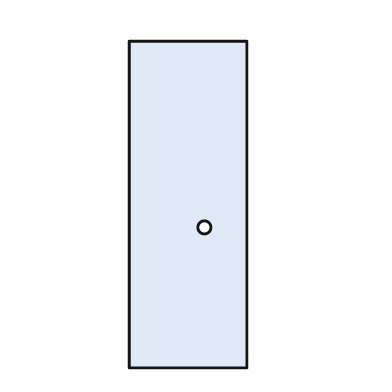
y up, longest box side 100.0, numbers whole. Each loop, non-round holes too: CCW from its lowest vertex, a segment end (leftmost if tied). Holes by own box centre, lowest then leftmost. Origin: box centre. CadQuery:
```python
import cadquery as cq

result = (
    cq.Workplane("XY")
    .moveTo(-18.0, -50.0)
    .lineTo(18.0, -50.0)
    .lineTo(18.0, 50.0)
    .lineTo(-18.0, 50.0)
    .close()
    .moveTo(5.0, -7.0)
    .circle(2.0)
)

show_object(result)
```